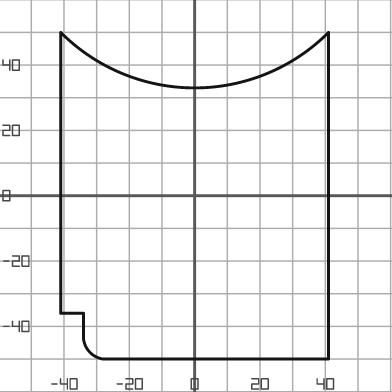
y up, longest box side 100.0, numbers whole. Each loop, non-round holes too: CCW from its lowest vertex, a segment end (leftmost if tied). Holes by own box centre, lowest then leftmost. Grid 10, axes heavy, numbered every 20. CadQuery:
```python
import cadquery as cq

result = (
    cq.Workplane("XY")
    .moveTo(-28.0, -50.0)
    .lineTo(41.0, -50.0)
    .lineTo(41.0, 50.0)
    .threePointArc((0.0, 33.0), (-41.0, 50.0))
    .lineTo(-41.0, -36.0)
    .lineTo(-34.0, -36.0)
    .lineTo(-34.0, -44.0)
    .threePointArc((-32.0, -48.0), (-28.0, -50.0))
    .close()
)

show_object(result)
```